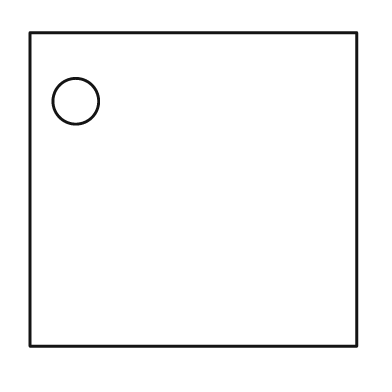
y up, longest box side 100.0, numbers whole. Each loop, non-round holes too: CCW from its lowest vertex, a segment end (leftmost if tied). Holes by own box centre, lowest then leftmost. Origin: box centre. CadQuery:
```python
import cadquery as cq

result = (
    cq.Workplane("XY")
    .moveTo(-50.0, -48.0)
    .lineTo(50.0, -48.0)
    .lineTo(50.0, 48.0)
    .lineTo(-50.0, 48.0)
    .close()
    .moveTo(-36.0, 27.0)
    .circle(7.0)
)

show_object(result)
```